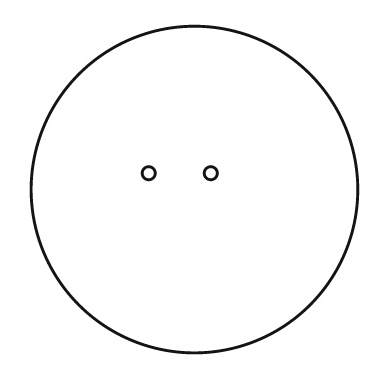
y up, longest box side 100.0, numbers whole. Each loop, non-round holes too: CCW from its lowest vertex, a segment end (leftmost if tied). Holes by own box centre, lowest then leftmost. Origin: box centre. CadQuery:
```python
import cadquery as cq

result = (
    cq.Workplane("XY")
    .moveTo(0.0, 0.0)
    .circle(50.0)
    .moveTo(-14.0, 5.0)
    .circle(2.0)
    .moveTo(5.0, 5.0)
    .circle(2.0)
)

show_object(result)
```